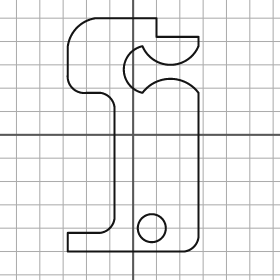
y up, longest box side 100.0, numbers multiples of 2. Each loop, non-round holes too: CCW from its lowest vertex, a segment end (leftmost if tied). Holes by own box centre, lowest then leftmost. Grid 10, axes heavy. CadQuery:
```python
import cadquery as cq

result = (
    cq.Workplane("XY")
    .moveTo(-28.0, -50.0)
    .lineTo(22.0, -50.0)
    .threePointArc((26.0, -48.0), (28.0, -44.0))
    .lineTo(28.0, 18.0)
    .threePointArc((16.0, 24.0), (4.0, 18.0))
    .threePointArc((-4.0, 28.0), (4.0, 38.0))
    .threePointArc((16.0, 30.0), (28.0, 38.0))
    .lineTo(28.0, 42.0)
    .lineTo(10.0, 42.0)
    .lineTo(10.0, 50.0)
    .lineTo(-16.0, 50.0)
    .threePointArc((-24.0, 46.0), (-28.0, 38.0))
    .lineTo(-28.0, 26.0)
    .threePointArc((-26.0, 20.0), (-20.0, 18.0))
    .lineTo(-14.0, 18.0)
    .threePointArc((-10.0, 16.0), (-8.0, 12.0))
    .lineTo(-8.0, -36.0)
    .threePointArc((-10.0, -40.0), (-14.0, -42.0))
    .lineTo(-28.0, -42.0)
    .close()
    .moveTo(8.0, -40.0)
    .circle(6.0)
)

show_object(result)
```